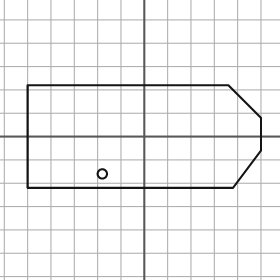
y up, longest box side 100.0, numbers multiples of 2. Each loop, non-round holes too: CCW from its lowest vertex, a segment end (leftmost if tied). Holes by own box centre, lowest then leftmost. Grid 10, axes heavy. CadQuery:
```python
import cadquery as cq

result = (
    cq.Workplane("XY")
    .moveTo(-50.0, -22.0)
    .lineTo(38.0, -22.0)
    .lineTo(50.0, -6.0)
    .lineTo(50.0, 8.0)
    .lineTo(36.0, 22.0)
    .lineTo(-50.0, 22.0)
    .close()
    .moveTo(-18.0, -16.0)
    .circle(2.0)
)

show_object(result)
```